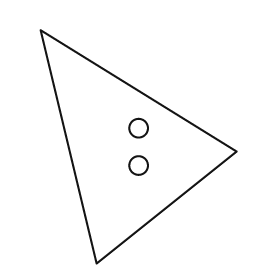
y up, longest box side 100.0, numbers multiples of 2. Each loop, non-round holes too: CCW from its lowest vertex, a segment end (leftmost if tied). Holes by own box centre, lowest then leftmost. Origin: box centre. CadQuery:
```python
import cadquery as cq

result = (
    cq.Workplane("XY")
    .moveTo(-18.0, -50.0)
    .lineTo(42.0, -2.0)
    .lineTo(-42.0, 50.0)
    .close()
    .moveTo(0.0, -8.0)
    .circle(4.0)
    .moveTo(0.0, 8.0)
    .circle(4.0)
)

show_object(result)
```